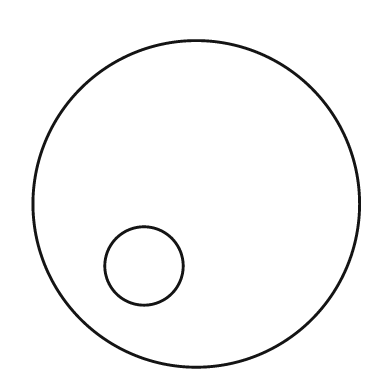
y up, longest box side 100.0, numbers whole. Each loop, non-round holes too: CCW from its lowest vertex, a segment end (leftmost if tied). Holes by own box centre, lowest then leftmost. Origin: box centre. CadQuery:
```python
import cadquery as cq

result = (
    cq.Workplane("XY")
    .moveTo(0.0, 0.0)
    .circle(50.0)
    .moveTo(-16.0, -19.0)
    .circle(12.0)
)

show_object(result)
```